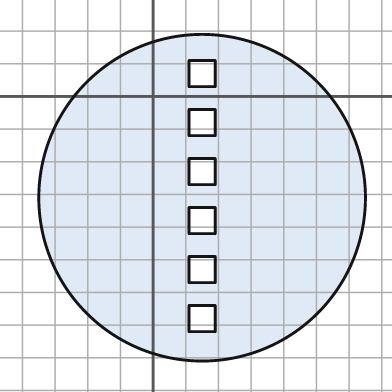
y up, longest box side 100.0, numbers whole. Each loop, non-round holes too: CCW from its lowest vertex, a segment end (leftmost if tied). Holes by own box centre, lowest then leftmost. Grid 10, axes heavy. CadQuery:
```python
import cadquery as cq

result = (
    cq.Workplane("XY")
    .moveTo(15.0, -31.0)
    .circle(50.0)
    .moveTo(11.0, -72.0)
    .lineTo(19.0, -72.0)
    .lineTo(19.0, -64.0)
    .lineTo(11.0, -64.0)
    .close()
    .moveTo(11.0, -57.0)
    .lineTo(19.0, -57.0)
    .lineTo(19.0, -49.0)
    .lineTo(11.0, -49.0)
    .close()
    .moveTo(11.0, -42.0)
    .lineTo(19.0, -42.0)
    .lineTo(19.0, -34.0)
    .lineTo(11.0, -34.0)
    .close()
    .moveTo(11.0, -27.0)
    .lineTo(19.0, -27.0)
    .lineTo(19.0, -19.0)
    .lineTo(11.0, -19.0)
    .close()
    .moveTo(11.0, -12.0)
    .lineTo(19.0, -12.0)
    .lineTo(19.0, -4.0)
    .lineTo(11.0, -4.0)
    .close()
    .moveTo(11.0, 3.0)
    .lineTo(19.0, 3.0)
    .lineTo(19.0, 11.0)
    .lineTo(11.0, 11.0)
    .close()
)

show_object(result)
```